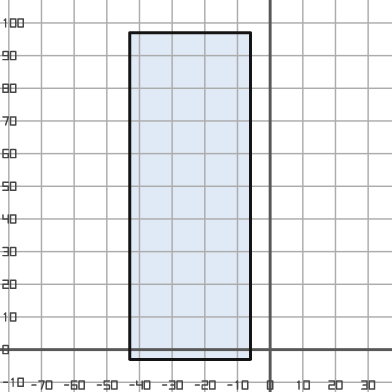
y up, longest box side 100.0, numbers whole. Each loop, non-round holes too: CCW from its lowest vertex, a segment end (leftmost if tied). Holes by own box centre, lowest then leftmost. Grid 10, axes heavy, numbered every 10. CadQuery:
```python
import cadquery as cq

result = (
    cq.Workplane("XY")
    .moveTo(-43.0, -3.0)
    .lineTo(-6.0, -3.0)
    .lineTo(-6.0, 97.0)
    .lineTo(-43.0, 97.0)
    .close()
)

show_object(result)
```